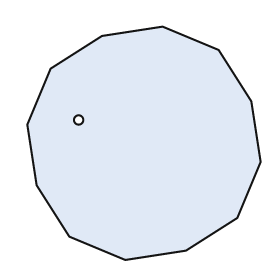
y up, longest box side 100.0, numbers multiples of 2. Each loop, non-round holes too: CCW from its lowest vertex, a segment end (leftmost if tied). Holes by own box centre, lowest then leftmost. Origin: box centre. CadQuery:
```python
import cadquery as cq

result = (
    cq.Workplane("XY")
    .moveTo(-8.0, -50.0)
    .lineTo(18.0, -46.0)
    .lineTo(40.0, -32.0)
    .lineTo(50.0, -8.0)
    .lineTo(46.0, 18.0)
    .lineTo(32.0, 40.0)
    .lineTo(8.0, 50.0)
    .lineTo(-18.0, 46.0)
    .lineTo(-40.0, 32.0)
    .lineTo(-50.0, 8.0)
    .lineTo(-46.0, -18.0)
    .lineTo(-32.0, -40.0)
    .close()
    .moveTo(-28.0, 10.0)
    .circle(2.0)
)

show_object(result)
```